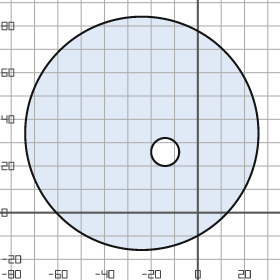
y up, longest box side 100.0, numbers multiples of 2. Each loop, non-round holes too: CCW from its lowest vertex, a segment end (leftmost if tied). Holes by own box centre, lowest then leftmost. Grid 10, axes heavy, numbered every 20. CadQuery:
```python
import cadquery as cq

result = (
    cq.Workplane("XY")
    .moveTo(-24.0, 34.0)
    .circle(50.0)
    .moveTo(-14.0, 26.0)
    .circle(6.0)
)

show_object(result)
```